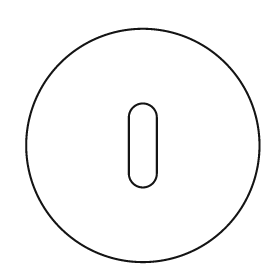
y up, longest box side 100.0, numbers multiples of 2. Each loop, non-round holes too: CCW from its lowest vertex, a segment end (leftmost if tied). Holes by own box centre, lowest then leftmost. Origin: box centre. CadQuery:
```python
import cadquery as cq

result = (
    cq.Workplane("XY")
    .moveTo(0.0, 0.0)
    .circle(50.0)
    .moveTo(-6.0, -12.0)
    .threePointArc((0.0, -18.0), (6.0, -12.0))
    .lineTo(6.0, 12.0)
    .threePointArc((0.0, 18.0), (-6.0, 12.0))
    .close()
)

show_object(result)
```